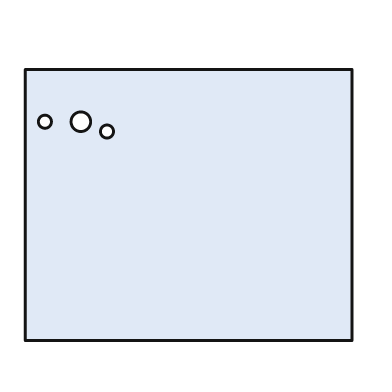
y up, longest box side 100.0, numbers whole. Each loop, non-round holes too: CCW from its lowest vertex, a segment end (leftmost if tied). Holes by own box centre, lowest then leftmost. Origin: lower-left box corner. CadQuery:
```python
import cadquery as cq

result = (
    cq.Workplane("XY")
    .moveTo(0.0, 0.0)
    .lineTo(100.0, 0.0)
    .lineTo(100.0, 83.0)
    .lineTo(0.0, 83.0)
    .close()
    .moveTo(25.0, 64.0)
    .circle(2.0)
    .moveTo(6.0, 67.0)
    .circle(2.0)
    .moveTo(17.0, 67.0)
    .circle(3.0)
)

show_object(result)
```